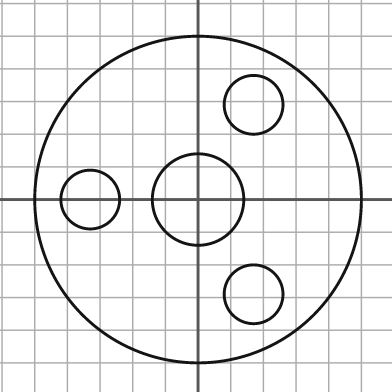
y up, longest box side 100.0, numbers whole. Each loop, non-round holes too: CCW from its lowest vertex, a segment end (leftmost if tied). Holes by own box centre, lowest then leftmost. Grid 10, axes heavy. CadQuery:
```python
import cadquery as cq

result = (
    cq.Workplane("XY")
    .moveTo(0.0, 0.0)
    .circle(50.0)
    .moveTo(17.0, -29.0)
    .circle(9.0)
    .moveTo(-33.0, 0.0)
    .circle(9.0)
    .moveTo(0.0, 0.0)
    .circle(14.0)
    .moveTo(17.0, 29.0)
    .circle(9.0)
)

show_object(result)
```